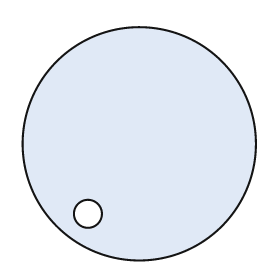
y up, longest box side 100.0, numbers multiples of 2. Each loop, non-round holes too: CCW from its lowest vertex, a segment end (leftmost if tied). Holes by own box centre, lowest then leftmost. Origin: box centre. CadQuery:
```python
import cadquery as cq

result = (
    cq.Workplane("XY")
    .moveTo(0.0, 0.0)
    .circle(50.0)
    .moveTo(-22.0, -30.0)
    .circle(6.0)
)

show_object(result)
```